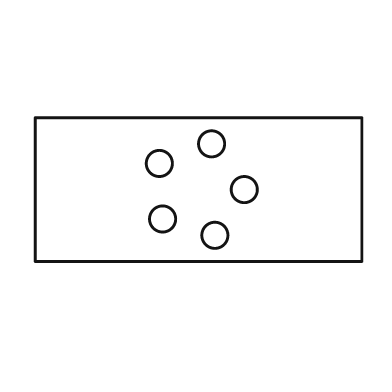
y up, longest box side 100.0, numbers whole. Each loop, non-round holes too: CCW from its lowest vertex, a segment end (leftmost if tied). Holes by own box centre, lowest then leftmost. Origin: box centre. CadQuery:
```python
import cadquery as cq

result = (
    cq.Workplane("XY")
    .moveTo(-50.0, -22.0)
    .lineTo(50.0, -22.0)
    .lineTo(50.0, 22.0)
    .lineTo(-50.0, 22.0)
    .close()
    .moveTo(5.0, -14.0)
    .circle(4.0)
    .moveTo(-11.0, -9.0)
    .circle(4.0)
    .moveTo(14.0, 0.0)
    .circle(4.0)
    .moveTo(-12.0, 8.0)
    .circle(4.0)
    .moveTo(4.0, 14.0)
    .circle(4.0)
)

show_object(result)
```